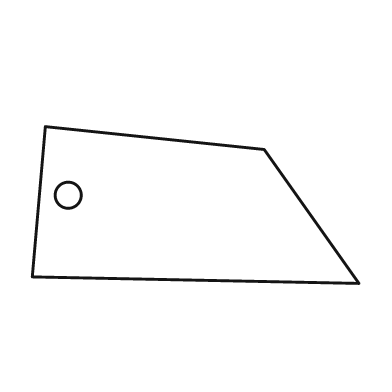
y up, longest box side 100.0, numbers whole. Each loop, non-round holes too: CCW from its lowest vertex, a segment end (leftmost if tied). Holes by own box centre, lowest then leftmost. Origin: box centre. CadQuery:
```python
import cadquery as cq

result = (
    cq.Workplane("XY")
    .moveTo(50.0, -24.0)
    .lineTo(21.0, 17.0)
    .lineTo(-46.0, 24.0)
    .lineTo(-50.0, -22.0)
    .close()
    .moveTo(-39.0, 3.0)
    .circle(4.0)
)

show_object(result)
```